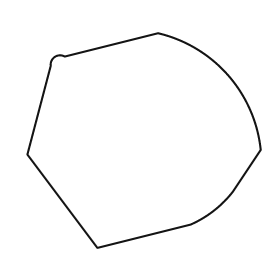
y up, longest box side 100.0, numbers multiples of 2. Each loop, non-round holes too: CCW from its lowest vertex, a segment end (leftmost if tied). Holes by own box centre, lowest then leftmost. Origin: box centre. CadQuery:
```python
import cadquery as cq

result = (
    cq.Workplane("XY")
    .moveTo(-20.0, -46.0)
    .lineTo(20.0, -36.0)
    .threePointArc((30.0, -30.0), (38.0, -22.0))
    .lineTo(50.0, -4.0)
    .threePointArc((36.0, 28.0), (6.0, 46.0))
    .lineTo(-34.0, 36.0)
    .threePointArc((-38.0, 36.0), (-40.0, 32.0))
    .lineTo(-50.0, -6.0)
    .close()
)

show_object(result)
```